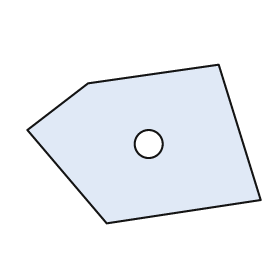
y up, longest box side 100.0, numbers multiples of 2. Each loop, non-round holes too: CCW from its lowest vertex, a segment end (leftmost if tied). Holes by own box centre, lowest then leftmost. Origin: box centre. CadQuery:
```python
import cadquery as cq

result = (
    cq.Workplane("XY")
    .moveTo(-16.0, -34.0)
    .lineTo(50.0, -24.0)
    .lineTo(32.0, 34.0)
    .lineTo(-24.0, 26.0)
    .lineTo(-50.0, 6.0)
    .close()
    .moveTo(2.0, 0.0)
    .circle(6.0)
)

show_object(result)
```